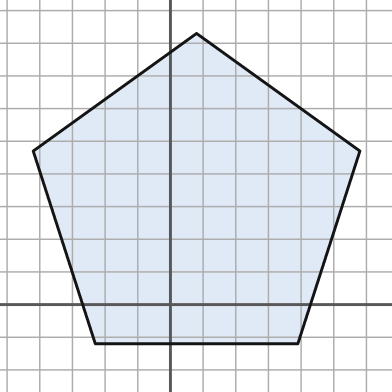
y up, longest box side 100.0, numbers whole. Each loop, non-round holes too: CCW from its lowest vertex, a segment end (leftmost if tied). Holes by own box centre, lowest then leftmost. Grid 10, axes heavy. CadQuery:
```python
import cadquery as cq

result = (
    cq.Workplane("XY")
    .moveTo(-23.0, -12.0)
    .lineTo(39.0, -12.0)
    .lineTo(58.0, 47.0)
    .lineTo(8.0, 83.0)
    .lineTo(-42.0, 47.0)
    .close()
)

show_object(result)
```